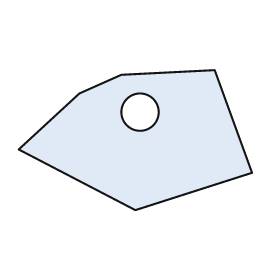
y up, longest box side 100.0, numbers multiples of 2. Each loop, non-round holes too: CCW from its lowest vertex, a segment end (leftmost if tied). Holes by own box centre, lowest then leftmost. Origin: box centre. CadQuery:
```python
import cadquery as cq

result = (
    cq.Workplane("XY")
    .moveTo(0.0, -30.0)
    .lineTo(50.0, -14.0)
    .lineTo(34.0, 30.0)
    .lineTo(-6.0, 28.0)
    .lineTo(-24.0, 20.0)
    .lineTo(-50.0, -4.0)
    .close()
    .moveTo(2.0, 12.0)
    .circle(8.0)
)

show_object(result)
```